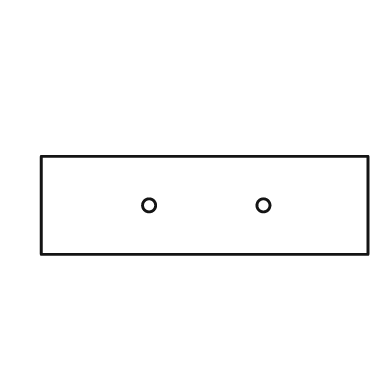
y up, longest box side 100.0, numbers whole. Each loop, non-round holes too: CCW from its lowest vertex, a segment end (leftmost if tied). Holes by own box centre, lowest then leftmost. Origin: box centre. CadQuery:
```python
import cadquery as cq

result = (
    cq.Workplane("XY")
    .moveTo(-50.0, -15.0)
    .lineTo(50.0, -15.0)
    .lineTo(50.0, 15.0)
    .lineTo(-50.0, 15.0)
    .close()
    .moveTo(-17.0, 0.0)
    .circle(2.0)
    .moveTo(18.0, 0.0)
    .circle(2.0)
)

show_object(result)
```